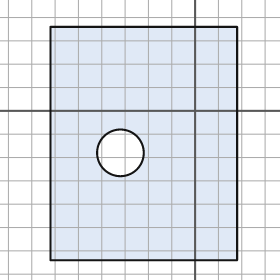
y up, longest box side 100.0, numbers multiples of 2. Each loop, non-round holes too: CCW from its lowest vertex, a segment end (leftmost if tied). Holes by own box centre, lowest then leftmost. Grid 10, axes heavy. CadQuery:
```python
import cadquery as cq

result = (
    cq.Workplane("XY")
    .moveTo(-62.0, -64.0)
    .lineTo(18.0, -64.0)
    .lineTo(18.0, 36.0)
    .lineTo(-62.0, 36.0)
    .close()
    .moveTo(-32.0, -18.0)
    .circle(10.0)
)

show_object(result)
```